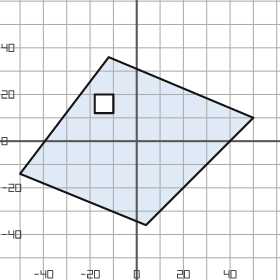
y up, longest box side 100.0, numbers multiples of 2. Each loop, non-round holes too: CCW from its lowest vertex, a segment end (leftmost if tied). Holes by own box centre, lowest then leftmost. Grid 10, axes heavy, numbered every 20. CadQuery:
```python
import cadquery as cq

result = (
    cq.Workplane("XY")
    .moveTo(4.0, -36.0)
    .lineTo(50.0, 10.0)
    .lineTo(-12.0, 36.0)
    .lineTo(-50.0, -14.0)
    .close()
    .moveTo(-18.0, 12.0)
    .lineTo(-10.0, 12.0)
    .lineTo(-10.0, 20.0)
    .lineTo(-18.0, 20.0)
    .close()
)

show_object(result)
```